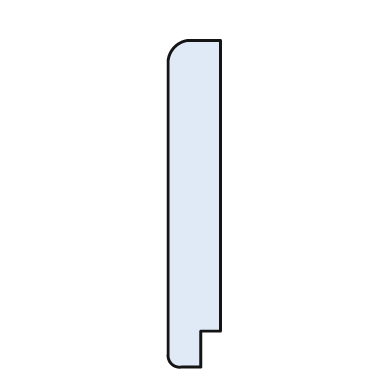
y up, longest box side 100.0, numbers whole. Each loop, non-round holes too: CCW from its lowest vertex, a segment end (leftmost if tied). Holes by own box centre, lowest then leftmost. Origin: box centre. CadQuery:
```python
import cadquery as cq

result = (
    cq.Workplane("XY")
    .moveTo(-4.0, -50.0)
    .lineTo(2.0, -50.0)
    .lineTo(2.0, -39.0)
    .lineTo(8.0, -39.0)
    .lineTo(8.0, 50.0)
    .lineTo(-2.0, 50.0)
    .threePointArc((-6.0, 48.0), (-8.0, 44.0))
    .lineTo(-8.0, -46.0)
    .threePointArc((-7.0, -49.0), (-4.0, -50.0))
    .close()
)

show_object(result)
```